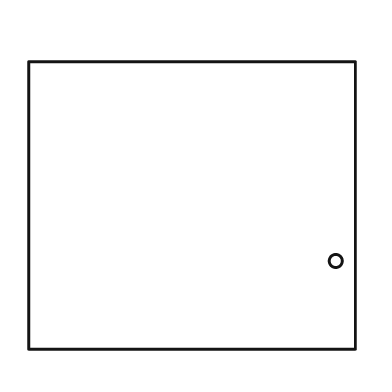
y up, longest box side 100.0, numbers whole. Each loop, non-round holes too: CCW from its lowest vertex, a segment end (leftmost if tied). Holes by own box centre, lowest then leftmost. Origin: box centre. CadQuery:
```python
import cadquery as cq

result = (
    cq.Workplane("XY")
    .moveTo(-50.0, -44.0)
    .lineTo(50.0, -44.0)
    .lineTo(50.0, 44.0)
    .lineTo(-50.0, 44.0)
    .close()
    .moveTo(44.0, -17.0)
    .circle(2.0)
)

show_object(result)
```